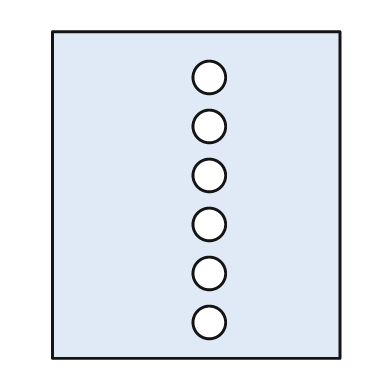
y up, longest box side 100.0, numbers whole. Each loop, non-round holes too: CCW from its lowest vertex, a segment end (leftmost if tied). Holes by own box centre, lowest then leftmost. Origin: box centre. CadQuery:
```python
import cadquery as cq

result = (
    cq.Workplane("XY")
    .moveTo(-44.0, -50.0)
    .lineTo(44.0, -50.0)
    .lineTo(44.0, 50.0)
    .lineTo(-44.0, 50.0)
    .close()
    .moveTo(4.0, -39.0)
    .circle(5.0)
    .moveTo(4.0, -24.0)
    .circle(5.0)
    .moveTo(4.0, -9.0)
    .circle(5.0)
    .moveTo(4.0, 6.0)
    .circle(5.0)
    .moveTo(4.0, 21.0)
    .circle(5.0)
    .moveTo(4.0, 36.0)
    .circle(5.0)
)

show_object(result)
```